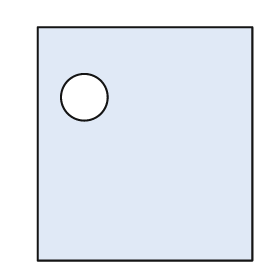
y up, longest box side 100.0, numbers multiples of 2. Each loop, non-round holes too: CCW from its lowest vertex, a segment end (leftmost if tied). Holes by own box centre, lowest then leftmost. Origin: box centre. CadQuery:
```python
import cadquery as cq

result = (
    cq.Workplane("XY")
    .moveTo(-46.0, -50.0)
    .lineTo(46.0, -50.0)
    .lineTo(46.0, 50.0)
    .lineTo(-46.0, 50.0)
    .close()
    .moveTo(-26.0, 20.0)
    .circle(10.0)
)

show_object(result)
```